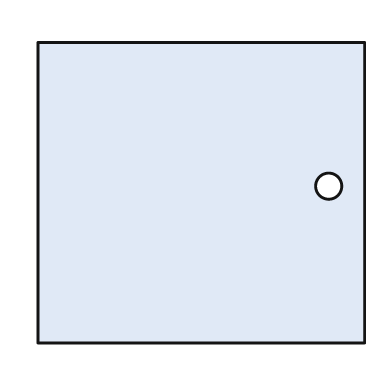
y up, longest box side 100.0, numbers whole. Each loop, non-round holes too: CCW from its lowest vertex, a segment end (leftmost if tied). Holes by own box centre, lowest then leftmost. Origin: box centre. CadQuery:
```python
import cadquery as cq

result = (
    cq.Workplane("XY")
    .moveTo(-50.0, -46.0)
    .lineTo(50.0, -46.0)
    .lineTo(50.0, 46.0)
    .lineTo(-50.0, 46.0)
    .close()
    .moveTo(39.0, 2.0)
    .circle(4.0)
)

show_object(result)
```